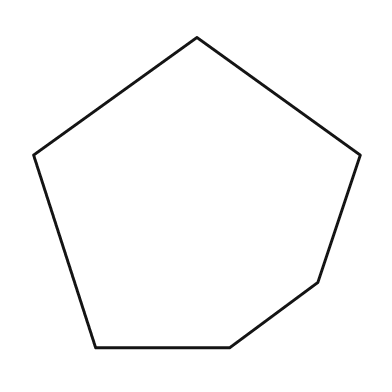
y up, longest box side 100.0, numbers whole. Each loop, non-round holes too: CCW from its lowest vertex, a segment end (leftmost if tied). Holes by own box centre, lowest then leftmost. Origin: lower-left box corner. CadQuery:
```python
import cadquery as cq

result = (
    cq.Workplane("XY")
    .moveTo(19.0, 0.0)
    .lineTo(60.0, 0.0)
    .lineTo(87.0, 20.0)
    .lineTo(100.0, 59.0)
    .lineTo(50.0, 95.0)
    .lineTo(0.0, 59.0)
    .close()
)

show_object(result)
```